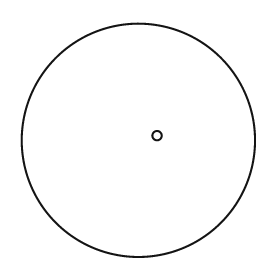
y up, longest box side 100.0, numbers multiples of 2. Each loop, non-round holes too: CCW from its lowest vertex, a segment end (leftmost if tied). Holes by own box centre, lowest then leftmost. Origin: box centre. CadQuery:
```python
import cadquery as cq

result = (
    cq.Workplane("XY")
    .moveTo(0.0, 0.0)
    .circle(50.0)
    .moveTo(8.0, 2.0)
    .circle(2.0)
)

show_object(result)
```